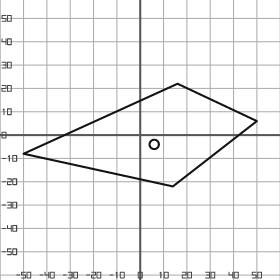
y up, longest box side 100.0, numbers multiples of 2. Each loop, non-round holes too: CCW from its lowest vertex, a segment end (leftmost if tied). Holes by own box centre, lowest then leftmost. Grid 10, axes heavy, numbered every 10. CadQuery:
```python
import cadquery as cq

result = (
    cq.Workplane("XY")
    .moveTo(14.0, -22.0)
    .lineTo(50.0, 6.0)
    .lineTo(16.0, 22.0)
    .lineTo(-50.0, -8.0)
    .close()
    .moveTo(6.0, -4.0)
    .circle(2.0)
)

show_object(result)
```